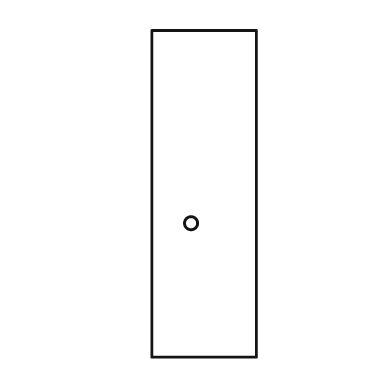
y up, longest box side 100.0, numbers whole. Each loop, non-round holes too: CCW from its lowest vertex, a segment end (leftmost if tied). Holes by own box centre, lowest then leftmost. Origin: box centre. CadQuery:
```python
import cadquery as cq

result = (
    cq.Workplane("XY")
    .moveTo(-16.0, -50.0)
    .lineTo(16.0, -50.0)
    .lineTo(16.0, 50.0)
    .lineTo(-16.0, 50.0)
    .close()
    .moveTo(-4.0, -9.0)
    .circle(2.0)
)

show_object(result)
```